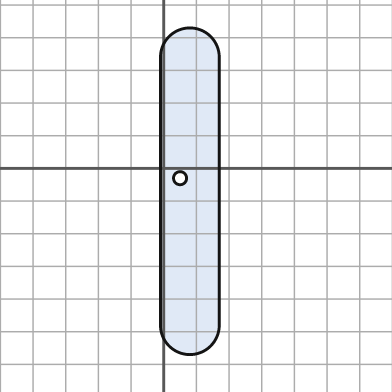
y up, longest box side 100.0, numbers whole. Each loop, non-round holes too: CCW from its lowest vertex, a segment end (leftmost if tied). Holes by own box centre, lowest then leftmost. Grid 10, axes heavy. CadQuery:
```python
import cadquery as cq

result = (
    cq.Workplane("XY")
    .moveTo(-1.0, -48.0)
    .threePointArc((8.0, -57.0), (17.0, -48.0))
    .lineTo(17.0, 34.0)
    .threePointArc((8.0, 43.0), (-1.0, 34.0))
    .close()
    .moveTo(5.0, -3.0)
    .circle(2.0)
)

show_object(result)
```